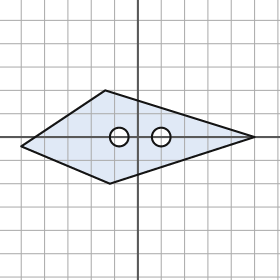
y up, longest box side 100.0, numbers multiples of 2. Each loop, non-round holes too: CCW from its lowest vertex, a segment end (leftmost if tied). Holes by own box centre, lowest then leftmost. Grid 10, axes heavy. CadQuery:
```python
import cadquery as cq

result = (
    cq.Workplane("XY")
    .moveTo(-12.0, -20.0)
    .lineTo(50.0, 0.0)
    .lineTo(-14.0, 20.0)
    .lineTo(-50.0, -4.0)
    .close()
    .moveTo(-8.0, 0.0)
    .circle(4.0)
    .moveTo(10.0, 0.0)
    .circle(4.0)
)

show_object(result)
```